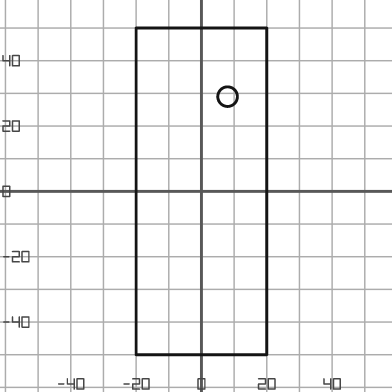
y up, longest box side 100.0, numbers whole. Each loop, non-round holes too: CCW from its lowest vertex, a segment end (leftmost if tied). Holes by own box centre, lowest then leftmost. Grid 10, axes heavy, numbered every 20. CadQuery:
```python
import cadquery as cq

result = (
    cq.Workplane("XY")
    .moveTo(-20.0, -50.0)
    .lineTo(20.0, -50.0)
    .lineTo(20.0, 50.0)
    .lineTo(-20.0, 50.0)
    .close()
    .moveTo(8.0, 29.0)
    .circle(3.0)
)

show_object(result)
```